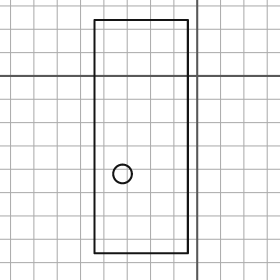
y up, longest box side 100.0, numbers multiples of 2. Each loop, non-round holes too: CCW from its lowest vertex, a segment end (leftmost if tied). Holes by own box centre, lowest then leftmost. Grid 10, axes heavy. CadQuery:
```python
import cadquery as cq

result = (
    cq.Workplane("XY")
    .moveTo(-44.0, -76.0)
    .lineTo(-4.0, -76.0)
    .lineTo(-4.0, 24.0)
    .lineTo(-44.0, 24.0)
    .close()
    .moveTo(-32.0, -42.0)
    .circle(4.0)
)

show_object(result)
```